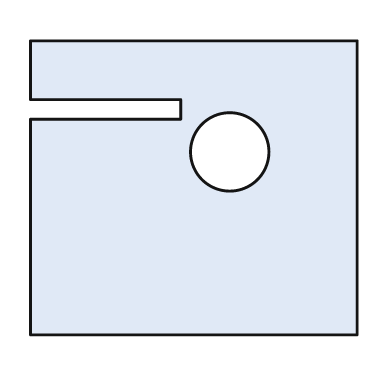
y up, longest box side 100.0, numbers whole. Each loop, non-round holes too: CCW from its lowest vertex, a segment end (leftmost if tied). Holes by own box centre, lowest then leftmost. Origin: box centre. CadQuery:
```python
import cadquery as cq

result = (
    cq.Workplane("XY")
    .moveTo(-50.0, -45.0)
    .lineTo(50.0, -45.0)
    .lineTo(50.0, 45.0)
    .lineTo(-50.0, 45.0)
    .lineTo(-50.0, 27.0)
    .lineTo(-4.0, 27.0)
    .lineTo(-4.0, 21.0)
    .lineTo(-50.0, 21.0)
    .close()
    .moveTo(11.0, 11.0)
    .circle(12.0)
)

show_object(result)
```